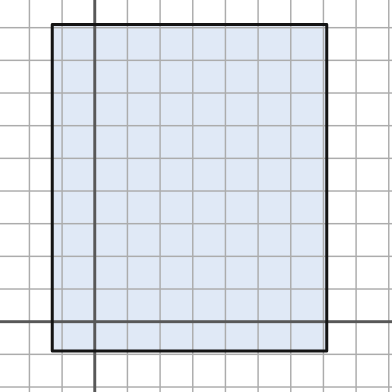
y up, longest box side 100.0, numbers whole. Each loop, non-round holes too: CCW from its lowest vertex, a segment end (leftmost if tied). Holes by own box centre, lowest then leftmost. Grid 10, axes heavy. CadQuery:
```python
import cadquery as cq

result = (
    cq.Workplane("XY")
    .moveTo(-13.0, -9.0)
    .lineTo(71.0, -9.0)
    .lineTo(71.0, 91.0)
    .lineTo(-13.0, 91.0)
    .close()
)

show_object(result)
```